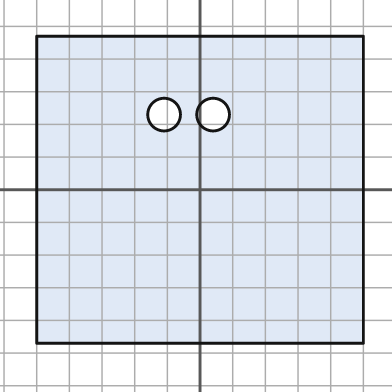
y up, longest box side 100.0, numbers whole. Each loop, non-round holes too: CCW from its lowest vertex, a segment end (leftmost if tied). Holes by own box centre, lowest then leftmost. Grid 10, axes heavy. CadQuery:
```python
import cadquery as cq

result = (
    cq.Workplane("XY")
    .moveTo(-50.0, -47.0)
    .lineTo(50.0, -47.0)
    .lineTo(50.0, 47.0)
    .lineTo(-50.0, 47.0)
    .close()
    .moveTo(-11.0, 23.0)
    .circle(5.0)
    .moveTo(4.0, 23.0)
    .circle(5.0)
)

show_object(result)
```